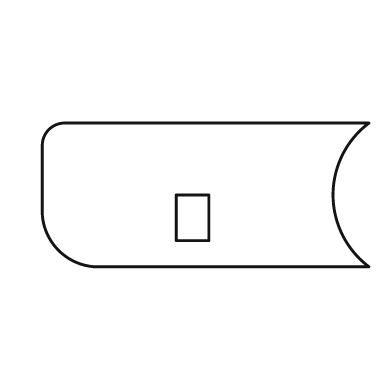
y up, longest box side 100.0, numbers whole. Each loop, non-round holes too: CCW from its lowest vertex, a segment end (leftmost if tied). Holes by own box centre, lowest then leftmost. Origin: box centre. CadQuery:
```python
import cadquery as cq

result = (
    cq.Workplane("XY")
    .moveTo(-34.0, -22.0)
    .lineTo(50.0, -22.0)
    .threePointArc((39.0, 0.0), (50.0, 22.0))
    .lineTo(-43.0, 22.0)
    .threePointArc((-48.0, 20.0), (-50.0, 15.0))
    .lineTo(-50.0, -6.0)
    .threePointArc((-45.0, -17.0), (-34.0, -22.0))
    .close()
    .moveTo(-9.0, -14.0)
    .lineTo(1.0, -14.0)
    .lineTo(1.0, 0.0)
    .lineTo(-9.0, 0.0)
    .close()
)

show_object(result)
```